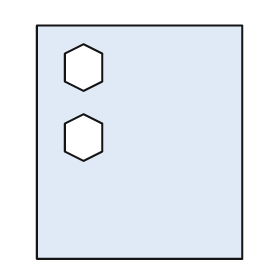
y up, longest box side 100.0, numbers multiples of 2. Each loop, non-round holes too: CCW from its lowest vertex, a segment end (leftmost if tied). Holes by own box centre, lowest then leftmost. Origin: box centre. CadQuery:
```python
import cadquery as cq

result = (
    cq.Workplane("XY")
    .moveTo(-44.0, -50.0)
    .lineTo(44.0, -50.0)
    .lineTo(44.0, 50.0)
    .lineTo(-44.0, 50.0)
    .close()
    .moveTo(-24.0, -8.0)
    .lineTo(-16.0, -4.0)
    .lineTo(-16.0, 8.0)
    .lineTo(-24.0, 12.0)
    .lineTo(-32.0, 8.0)
    .lineTo(-32.0, -4.0)
    .close()
    .moveTo(-24.0, 22.0)
    .lineTo(-16.0, 26.0)
    .lineTo(-16.0, 38.0)
    .lineTo(-24.0, 42.0)
    .lineTo(-32.0, 38.0)
    .lineTo(-32.0, 26.0)
    .close()
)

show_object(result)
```